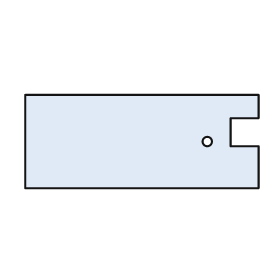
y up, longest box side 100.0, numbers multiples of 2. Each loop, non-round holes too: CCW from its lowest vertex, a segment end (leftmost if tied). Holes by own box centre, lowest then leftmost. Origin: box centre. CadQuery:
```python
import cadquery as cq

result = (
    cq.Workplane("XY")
    .moveTo(-50.0, -20.0)
    .lineTo(50.0, -20.0)
    .lineTo(50.0, -2.0)
    .lineTo(38.0, -2.0)
    .lineTo(38.0, 10.0)
    .lineTo(50.0, 10.0)
    .lineTo(50.0, 20.0)
    .lineTo(-50.0, 20.0)
    .close()
    .moveTo(28.0, 0.0)
    .circle(2.0)
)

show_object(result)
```